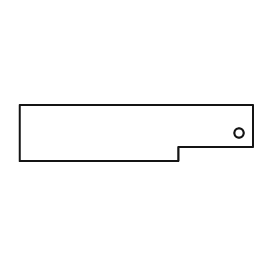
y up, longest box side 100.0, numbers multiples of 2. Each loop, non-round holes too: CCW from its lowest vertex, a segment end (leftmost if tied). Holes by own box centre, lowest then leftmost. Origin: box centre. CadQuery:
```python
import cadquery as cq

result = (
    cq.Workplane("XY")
    .moveTo(-50.0, -12.0)
    .lineTo(18.0, -12.0)
    .lineTo(18.0, -6.0)
    .lineTo(50.0, -6.0)
    .lineTo(50.0, 12.0)
    .lineTo(-50.0, 12.0)
    .close()
    .moveTo(44.0, 0.0)
    .circle(2.0)
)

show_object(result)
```